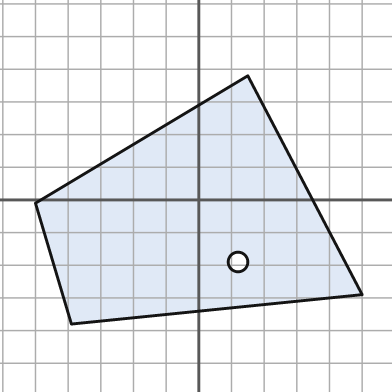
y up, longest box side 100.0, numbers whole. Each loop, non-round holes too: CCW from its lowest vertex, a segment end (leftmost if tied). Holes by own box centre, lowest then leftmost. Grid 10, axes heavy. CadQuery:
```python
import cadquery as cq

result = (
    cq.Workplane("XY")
    .moveTo(-39.0, -38.0)
    .lineTo(50.0, -29.0)
    .lineTo(15.0, 38.0)
    .lineTo(-50.0, -1.0)
    .close()
    .moveTo(12.0, -19.0)
    .circle(3.0)
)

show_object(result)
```